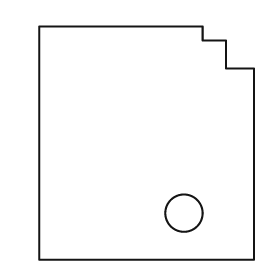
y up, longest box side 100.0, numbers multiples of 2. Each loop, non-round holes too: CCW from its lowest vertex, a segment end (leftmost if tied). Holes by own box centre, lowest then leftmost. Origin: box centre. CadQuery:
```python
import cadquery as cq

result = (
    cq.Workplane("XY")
    .moveTo(-46.0, -50.0)
    .lineTo(46.0, -50.0)
    .lineTo(46.0, 32.0)
    .lineTo(34.0, 32.0)
    .lineTo(34.0, 44.0)
    .lineTo(24.0, 44.0)
    .lineTo(24.0, 50.0)
    .lineTo(-46.0, 50.0)
    .close()
    .moveTo(16.0, -30.0)
    .circle(8.0)
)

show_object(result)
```